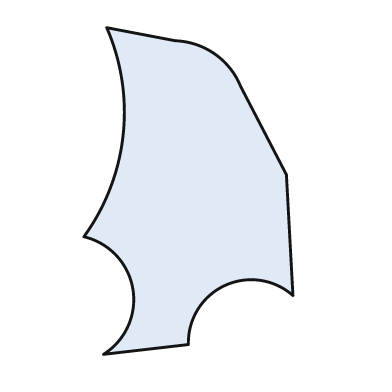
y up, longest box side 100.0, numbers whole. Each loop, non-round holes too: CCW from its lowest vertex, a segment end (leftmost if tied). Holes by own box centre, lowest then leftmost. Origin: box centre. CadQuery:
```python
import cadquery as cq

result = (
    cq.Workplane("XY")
    .moveTo(-26.0, -50.0)
    .lineTo(0.0, -47.0)
    .threePointArc((11.0, -29.0), (32.0, -32.0))
    .lineTo(30.0, 5.0)
    .lineTo(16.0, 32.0)
    .threePointArc((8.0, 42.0), (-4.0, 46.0))
    .lineTo(-25.0, 50.0)
    .threePointArc((-20.0, 17.0), (-32.0, -14.0))
    .threePointArc((-17.0, -30.0), (-26.0, -50.0))
    .close()
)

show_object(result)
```